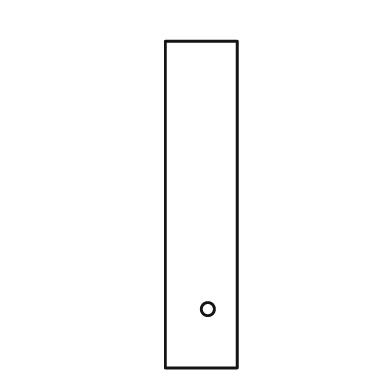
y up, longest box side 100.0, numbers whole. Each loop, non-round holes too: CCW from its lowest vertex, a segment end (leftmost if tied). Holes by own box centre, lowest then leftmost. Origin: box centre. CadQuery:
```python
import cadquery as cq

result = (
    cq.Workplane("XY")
    .moveTo(-11.0, -50.0)
    .lineTo(11.0, -50.0)
    .lineTo(11.0, 50.0)
    .lineTo(-11.0, 50.0)
    .close()
    .moveTo(2.0, -32.0)
    .circle(2.0)
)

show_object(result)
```